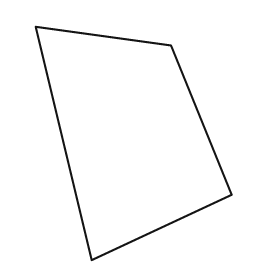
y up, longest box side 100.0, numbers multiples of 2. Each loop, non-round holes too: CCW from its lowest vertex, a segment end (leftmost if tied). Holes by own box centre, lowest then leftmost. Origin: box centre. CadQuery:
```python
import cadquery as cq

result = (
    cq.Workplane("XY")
    .moveTo(-18.0, -50.0)
    .lineTo(42.0, -22.0)
    .lineTo(16.0, 42.0)
    .lineTo(-42.0, 50.0)
    .close()
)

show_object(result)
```